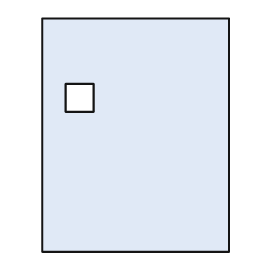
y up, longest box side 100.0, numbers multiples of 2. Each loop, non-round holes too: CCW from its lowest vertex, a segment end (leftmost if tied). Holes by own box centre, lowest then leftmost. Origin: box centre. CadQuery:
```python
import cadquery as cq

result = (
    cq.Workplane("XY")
    .moveTo(-40.0, -50.0)
    .lineTo(40.0, -50.0)
    .lineTo(40.0, 50.0)
    .lineTo(-40.0, 50.0)
    .close()
    .moveTo(-30.0, 10.0)
    .lineTo(-18.0, 10.0)
    .lineTo(-18.0, 22.0)
    .lineTo(-30.0, 22.0)
    .close()
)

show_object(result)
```